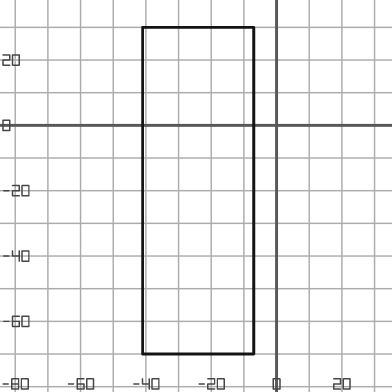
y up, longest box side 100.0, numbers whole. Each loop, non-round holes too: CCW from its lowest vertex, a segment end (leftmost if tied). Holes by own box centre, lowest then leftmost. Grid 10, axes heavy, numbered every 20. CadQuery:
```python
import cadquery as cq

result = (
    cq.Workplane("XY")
    .moveTo(-41.0, -70.0)
    .lineTo(-7.0, -70.0)
    .lineTo(-7.0, 30.0)
    .lineTo(-41.0, 30.0)
    .close()
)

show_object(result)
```